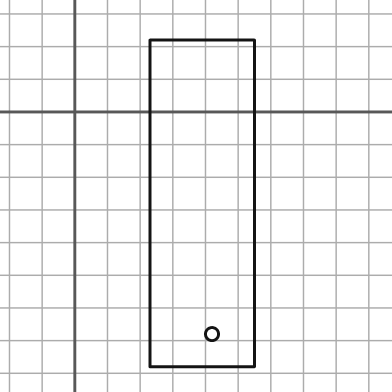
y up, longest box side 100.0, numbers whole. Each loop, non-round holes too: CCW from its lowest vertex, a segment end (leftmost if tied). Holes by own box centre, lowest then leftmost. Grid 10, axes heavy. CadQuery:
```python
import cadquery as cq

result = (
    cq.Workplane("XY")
    .moveTo(23.0, -78.0)
    .lineTo(55.0, -78.0)
    .lineTo(55.0, 22.0)
    .lineTo(23.0, 22.0)
    .close()
    .moveTo(42.0, -68.0)
    .circle(2.0)
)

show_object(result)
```